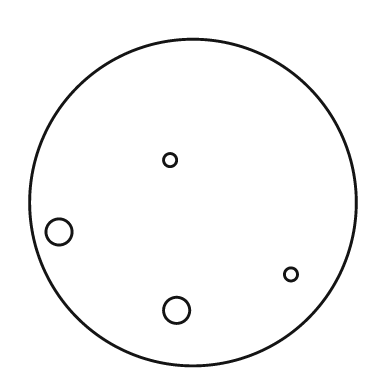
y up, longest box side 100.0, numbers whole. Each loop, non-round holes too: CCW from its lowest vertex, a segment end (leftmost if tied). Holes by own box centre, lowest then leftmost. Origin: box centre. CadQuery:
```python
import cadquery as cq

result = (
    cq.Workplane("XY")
    .moveTo(0.0, 0.0)
    .circle(50.0)
    .moveTo(-5.0, -33.0)
    .circle(4.0)
    .moveTo(30.0, -22.0)
    .circle(2.0)
    .moveTo(-41.0, -9.0)
    .circle(4.0)
    .moveTo(-7.0, 13.0)
    .circle(2.0)
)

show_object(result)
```